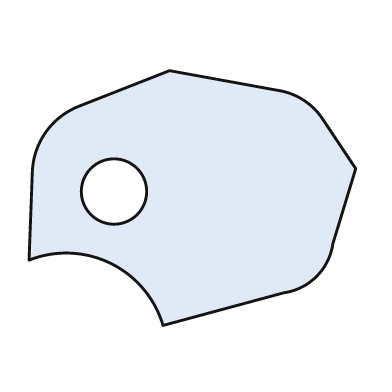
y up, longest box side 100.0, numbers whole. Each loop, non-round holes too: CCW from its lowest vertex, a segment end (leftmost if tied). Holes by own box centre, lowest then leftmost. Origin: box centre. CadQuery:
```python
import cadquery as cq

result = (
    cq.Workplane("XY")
    .moveTo(-9.0, -39.0)
    .lineTo(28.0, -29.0)
    .threePointArc((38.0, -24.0), (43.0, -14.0))
    .lineTo(50.0, 9.0)
    .lineTo(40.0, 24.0)
    .threePointArc((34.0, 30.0), (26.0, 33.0))
    .lineTo(-7.0, 39.0)
    .lineTo(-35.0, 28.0)
    .threePointArc((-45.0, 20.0), (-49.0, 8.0))
    .lineTo(-50.0, -19.0)
    .threePointArc((-25.0, -20.0), (-9.0, -39.0))
    .close()
    .moveTo(-24.0, 2.0)
    .circle(10.0)
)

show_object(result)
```